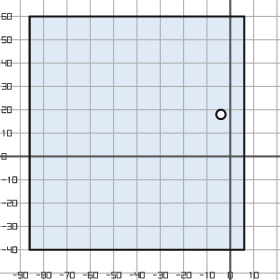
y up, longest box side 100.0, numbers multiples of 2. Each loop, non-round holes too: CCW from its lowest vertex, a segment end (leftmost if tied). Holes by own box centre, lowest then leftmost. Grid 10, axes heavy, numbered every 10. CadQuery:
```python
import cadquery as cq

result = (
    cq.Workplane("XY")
    .moveTo(-86.0, -40.0)
    .lineTo(6.0, -40.0)
    .lineTo(6.0, 60.0)
    .lineTo(-86.0, 60.0)
    .close()
    .moveTo(-4.0, 18.0)
    .circle(2.0)
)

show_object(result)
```